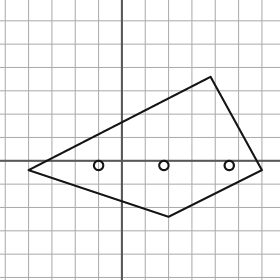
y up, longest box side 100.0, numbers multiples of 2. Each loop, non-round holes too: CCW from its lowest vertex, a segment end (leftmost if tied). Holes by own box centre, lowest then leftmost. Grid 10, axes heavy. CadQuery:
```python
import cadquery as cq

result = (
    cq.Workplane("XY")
    .moveTo(20.0, -24.0)
    .lineTo(60.0, -4.0)
    .lineTo(38.0, 36.0)
    .lineTo(-40.0, -4.0)
    .close()
    .moveTo(-10.0, -2.0)
    .circle(2.0)
    .moveTo(18.0, -2.0)
    .circle(2.0)
    .moveTo(46.0, -2.0)
    .circle(2.0)
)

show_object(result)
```